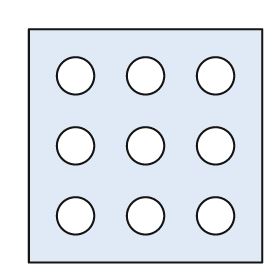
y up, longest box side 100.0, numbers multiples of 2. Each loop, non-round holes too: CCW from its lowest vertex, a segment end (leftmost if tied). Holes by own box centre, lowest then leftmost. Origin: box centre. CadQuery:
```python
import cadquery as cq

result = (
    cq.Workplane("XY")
    .moveTo(-50.0, -50.0)
    .lineTo(50.0, -50.0)
    .lineTo(50.0, 50.0)
    .lineTo(-50.0, 50.0)
    .close()
    .moveTo(-30.0, -30.0)
    .circle(8.0)
    .moveTo(0.0, -30.0)
    .circle(8.0)
    .moveTo(30.0, -30.0)
    .circle(8.0)
    .moveTo(-30.0, 0.0)
    .circle(8.0)
    .moveTo(0.0, 0.0)
    .circle(8.0)
    .moveTo(30.0, 0.0)
    .circle(8.0)
    .moveTo(-30.0, 30.0)
    .circle(8.0)
    .moveTo(0.0, 30.0)
    .circle(8.0)
    .moveTo(30.0, 30.0)
    .circle(8.0)
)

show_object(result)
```